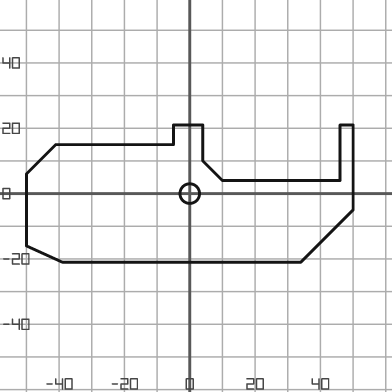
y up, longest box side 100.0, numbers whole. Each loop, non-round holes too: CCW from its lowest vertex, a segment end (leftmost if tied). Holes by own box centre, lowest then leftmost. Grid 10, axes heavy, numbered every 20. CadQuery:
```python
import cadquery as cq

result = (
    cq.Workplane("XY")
    .moveTo(-39.0, -21.0)
    .lineTo(34.0, -21.0)
    .lineTo(50.0, -5.0)
    .lineTo(50.0, 21.0)
    .lineTo(46.0, 21.0)
    .lineTo(46.0, 4.0)
    .lineTo(10.0, 4.0)
    .lineTo(4.0, 10.0)
    .lineTo(4.0, 21.0)
    .lineTo(-5.0, 21.0)
    .lineTo(-5.0, 15.0)
    .lineTo(-41.0, 15.0)
    .lineTo(-50.0, 6.0)
    .lineTo(-50.0, -16.0)
    .close()
    .moveTo(0.0, 0.0)
    .circle(3.0)
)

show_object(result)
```